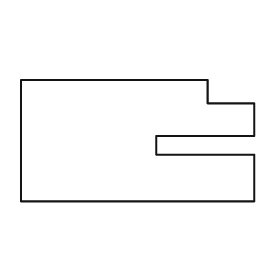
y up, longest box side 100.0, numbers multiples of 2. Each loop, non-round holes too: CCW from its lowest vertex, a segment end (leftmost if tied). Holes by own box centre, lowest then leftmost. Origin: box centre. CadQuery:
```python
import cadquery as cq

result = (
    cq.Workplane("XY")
    .moveTo(-50.0, -26.0)
    .lineTo(50.0, -26.0)
    .lineTo(50.0, -6.0)
    .lineTo(8.0, -6.0)
    .lineTo(8.0, 2.0)
    .lineTo(50.0, 2.0)
    .lineTo(50.0, 16.0)
    .lineTo(30.0, 16.0)
    .lineTo(30.0, 26.0)
    .lineTo(-50.0, 26.0)
    .close()
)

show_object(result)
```